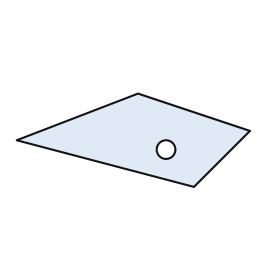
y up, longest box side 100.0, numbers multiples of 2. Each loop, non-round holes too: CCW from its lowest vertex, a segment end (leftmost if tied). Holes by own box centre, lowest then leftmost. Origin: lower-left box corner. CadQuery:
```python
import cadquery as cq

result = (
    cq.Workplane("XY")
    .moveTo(76.0, 0.0)
    .lineTo(100.0, 24.0)
    .lineTo(52.0, 40.0)
    .lineTo(0.0, 20.0)
    .close()
    .moveTo(64.0, 16.0)
    .circle(4.0)
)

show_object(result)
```